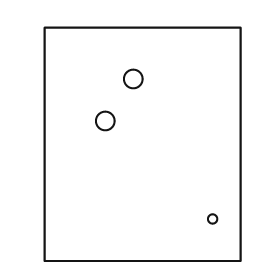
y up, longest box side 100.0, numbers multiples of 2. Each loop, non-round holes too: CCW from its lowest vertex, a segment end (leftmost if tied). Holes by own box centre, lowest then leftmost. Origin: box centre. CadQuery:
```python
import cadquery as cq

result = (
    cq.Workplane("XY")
    .moveTo(-42.0, -50.0)
    .lineTo(42.0, -50.0)
    .lineTo(42.0, 50.0)
    .lineTo(-42.0, 50.0)
    .close()
    .moveTo(30.0, -32.0)
    .circle(2.0)
    .moveTo(-16.0, 10.0)
    .circle(4.0)
    .moveTo(-4.0, 28.0)
    .circle(4.0)
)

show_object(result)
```